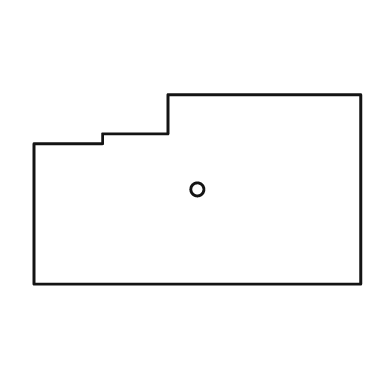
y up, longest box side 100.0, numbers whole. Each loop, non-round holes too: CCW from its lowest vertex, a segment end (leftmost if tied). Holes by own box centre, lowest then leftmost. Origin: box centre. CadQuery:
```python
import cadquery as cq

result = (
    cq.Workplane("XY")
    .moveTo(-50.0, -29.0)
    .lineTo(50.0, -29.0)
    .lineTo(50.0, 29.0)
    .lineTo(-9.0, 29.0)
    .lineTo(-9.0, 17.0)
    .lineTo(-29.0, 17.0)
    .lineTo(-29.0, 14.0)
    .lineTo(-50.0, 14.0)
    .close()
    .moveTo(0.0, 0.0)
    .circle(2.0)
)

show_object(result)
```